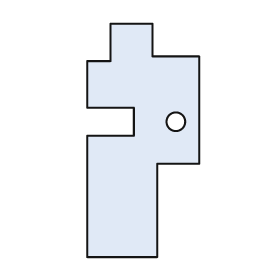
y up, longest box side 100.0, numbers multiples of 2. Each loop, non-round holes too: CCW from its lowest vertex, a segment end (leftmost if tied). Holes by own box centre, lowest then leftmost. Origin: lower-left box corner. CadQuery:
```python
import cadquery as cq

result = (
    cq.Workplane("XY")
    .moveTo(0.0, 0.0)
    .lineTo(30.0, 0.0)
    .lineTo(30.0, 40.0)
    .lineTo(48.0, 40.0)
    .lineTo(48.0, 86.0)
    .lineTo(28.0, 86.0)
    .lineTo(28.0, 100.0)
    .lineTo(10.0, 100.0)
    .lineTo(10.0, 84.0)
    .lineTo(0.0, 84.0)
    .lineTo(0.0, 64.0)
    .lineTo(20.0, 64.0)
    .lineTo(20.0, 52.0)
    .lineTo(0.0, 52.0)
    .close()
    .moveTo(38.0, 58.0)
    .circle(4.0)
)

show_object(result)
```